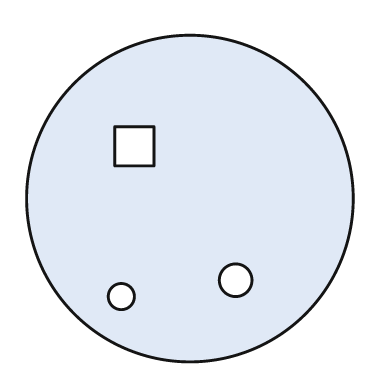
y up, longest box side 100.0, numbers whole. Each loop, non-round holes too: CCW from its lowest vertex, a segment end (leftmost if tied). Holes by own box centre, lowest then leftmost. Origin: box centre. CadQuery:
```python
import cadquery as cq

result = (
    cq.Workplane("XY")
    .moveTo(0.0, 0.0)
    .circle(50.0)
    .moveTo(-21.0, -30.0)
    .circle(4.0)
    .moveTo(14.0, -25.0)
    .circle(5.0)
    .moveTo(-23.0, 10.0)
    .lineTo(-11.0, 10.0)
    .lineTo(-11.0, 22.0)
    .lineTo(-23.0, 22.0)
    .close()
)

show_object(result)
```